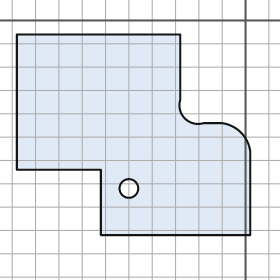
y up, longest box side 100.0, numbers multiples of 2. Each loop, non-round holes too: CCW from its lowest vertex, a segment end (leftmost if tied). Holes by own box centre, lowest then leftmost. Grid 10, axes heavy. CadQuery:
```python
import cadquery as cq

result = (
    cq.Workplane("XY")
    .moveTo(-62.0, -92.0)
    .lineTo(2.0, -92.0)
    .lineTo(2.0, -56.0)
    .threePointArc((-2.0, -48.0), (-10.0, -44.0))
    .lineTo(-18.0, -44.0)
    .threePointArc((-26.0, -42.0), (-28.0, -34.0))
    .lineTo(-28.0, -6.0)
    .lineTo(-98.0, -6.0)
    .lineTo(-98.0, -64.0)
    .lineTo(-62.0, -64.0)
    .close()
    .moveTo(-50.0, -72.0)
    .circle(4.0)
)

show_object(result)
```